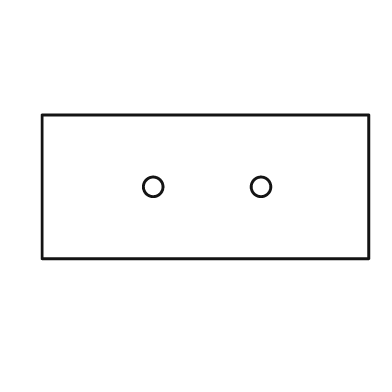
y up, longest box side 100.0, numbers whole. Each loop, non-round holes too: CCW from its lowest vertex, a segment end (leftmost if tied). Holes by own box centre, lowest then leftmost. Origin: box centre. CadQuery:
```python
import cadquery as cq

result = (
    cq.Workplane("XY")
    .moveTo(-50.0, -22.0)
    .lineTo(50.0, -22.0)
    .lineTo(50.0, 22.0)
    .lineTo(-50.0, 22.0)
    .close()
    .moveTo(-16.0, 0.0)
    .circle(3.0)
    .moveTo(17.0, 0.0)
    .circle(3.0)
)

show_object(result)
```